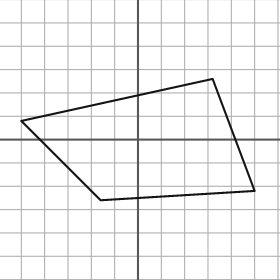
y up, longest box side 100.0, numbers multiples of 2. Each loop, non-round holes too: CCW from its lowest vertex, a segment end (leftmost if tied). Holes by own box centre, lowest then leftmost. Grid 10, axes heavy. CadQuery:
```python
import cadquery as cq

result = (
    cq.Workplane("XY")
    .moveTo(-16.0, -26.0)
    .lineTo(50.0, -22.0)
    .lineTo(32.0, 26.0)
    .lineTo(-50.0, 8.0)
    .close()
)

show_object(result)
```